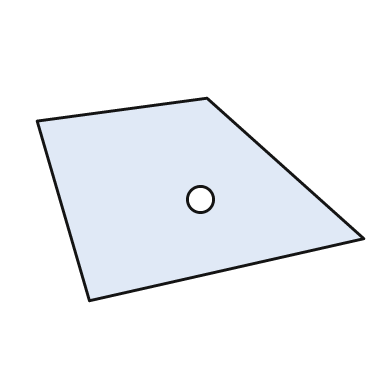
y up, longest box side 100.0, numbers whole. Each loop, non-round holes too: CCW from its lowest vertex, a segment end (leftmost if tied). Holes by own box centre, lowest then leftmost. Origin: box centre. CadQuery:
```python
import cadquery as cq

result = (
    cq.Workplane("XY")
    .moveTo(-34.0, -31.0)
    .lineTo(50.0, -12.0)
    .lineTo(2.0, 31.0)
    .lineTo(-50.0, 24.0)
    .close()
    .moveTo(0.0, 0.0)
    .circle(4.0)
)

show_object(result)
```